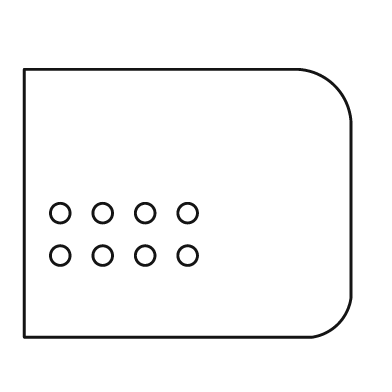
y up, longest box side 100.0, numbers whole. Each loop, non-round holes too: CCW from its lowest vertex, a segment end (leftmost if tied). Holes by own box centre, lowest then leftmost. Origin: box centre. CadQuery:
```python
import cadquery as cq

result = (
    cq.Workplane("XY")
    .moveTo(-50.0, -41.0)
    .lineTo(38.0, -41.0)
    .threePointArc((46.0, -37.0), (50.0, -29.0))
    .lineTo(50.0, 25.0)
    .threePointArc((45.0, 36.0), (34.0, 41.0))
    .lineTo(-50.0, 41.0)
    .close()
    .moveTo(-39.0, -16.0)
    .circle(3.0)
    .moveTo(-26.0, -16.0)
    .circle(3.0)
    .moveTo(-13.0, -16.0)
    .circle(3.0)
    .moveTo(0.0, -16.0)
    .circle(3.0)
    .moveTo(-39.0, -3.0)
    .circle(3.0)
    .moveTo(-26.0, -3.0)
    .circle(3.0)
    .moveTo(-13.0, -3.0)
    .circle(3.0)
    .moveTo(0.0, -3.0)
    .circle(3.0)
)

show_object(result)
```